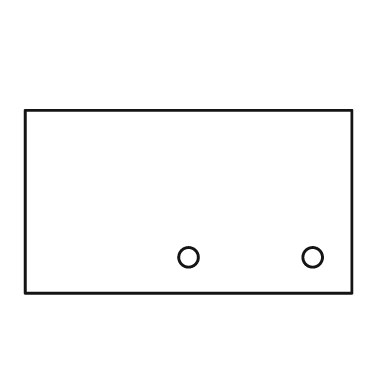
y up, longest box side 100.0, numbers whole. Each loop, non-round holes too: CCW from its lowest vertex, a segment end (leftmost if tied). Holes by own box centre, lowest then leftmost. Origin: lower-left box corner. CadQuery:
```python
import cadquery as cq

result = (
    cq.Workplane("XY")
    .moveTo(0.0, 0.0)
    .lineTo(100.0, 0.0)
    .lineTo(100.0, 56.0)
    .lineTo(0.0, 56.0)
    .close()
    .moveTo(50.0, 11.0)
    .circle(3.0)
    .moveTo(88.0, 11.0)
    .circle(3.0)
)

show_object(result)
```